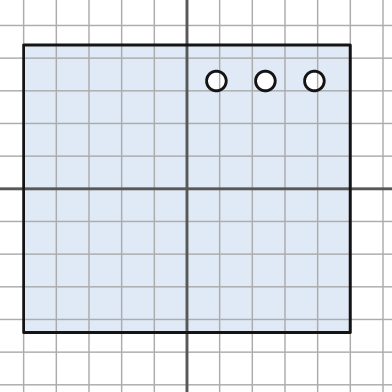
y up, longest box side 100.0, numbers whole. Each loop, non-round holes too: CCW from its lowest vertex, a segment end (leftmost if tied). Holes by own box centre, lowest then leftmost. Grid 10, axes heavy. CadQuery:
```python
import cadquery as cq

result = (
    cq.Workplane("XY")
    .moveTo(-50.0, -44.0)
    .lineTo(50.0, -44.0)
    .lineTo(50.0, 44.0)
    .lineTo(-50.0, 44.0)
    .close()
    .moveTo(9.0, 33.0)
    .circle(3.0)
    .moveTo(24.0, 33.0)
    .circle(3.0)
    .moveTo(39.0, 33.0)
    .circle(3.0)
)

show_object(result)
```